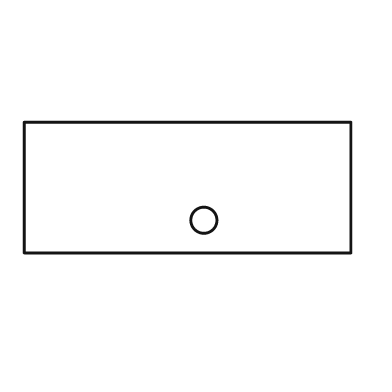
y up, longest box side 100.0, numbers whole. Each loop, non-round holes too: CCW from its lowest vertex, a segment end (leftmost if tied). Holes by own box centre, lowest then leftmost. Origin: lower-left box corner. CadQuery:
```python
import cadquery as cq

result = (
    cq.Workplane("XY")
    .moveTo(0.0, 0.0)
    .lineTo(100.0, 0.0)
    .lineTo(100.0, 40.0)
    .lineTo(0.0, 40.0)
    .close()
    .moveTo(55.0, 10.0)
    .circle(4.0)
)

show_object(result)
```